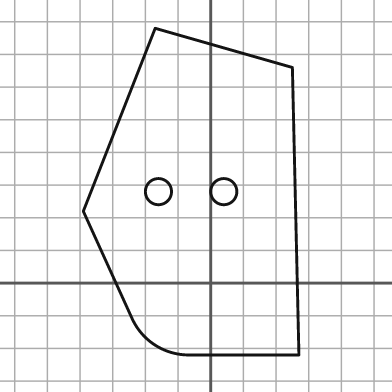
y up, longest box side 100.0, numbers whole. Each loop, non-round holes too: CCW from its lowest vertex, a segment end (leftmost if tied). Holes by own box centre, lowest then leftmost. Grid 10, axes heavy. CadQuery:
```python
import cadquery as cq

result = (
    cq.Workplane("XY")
    .moveTo(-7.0, -22.0)
    .lineTo(27.0, -22.0)
    .lineTo(25.0, 66.0)
    .lineTo(-17.0, 78.0)
    .lineTo(-39.0, 22.0)
    .lineTo(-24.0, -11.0)
    .threePointArc((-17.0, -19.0), (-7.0, -22.0))
    .close()
    .moveTo(-16.0, 28.0)
    .circle(4.0)
    .moveTo(4.0, 28.0)
    .circle(4.0)
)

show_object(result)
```